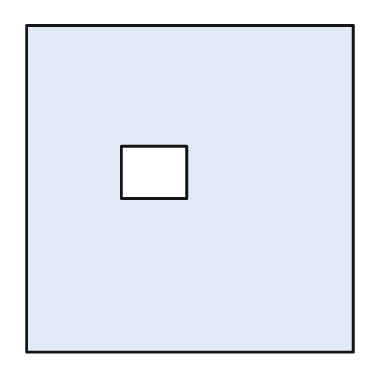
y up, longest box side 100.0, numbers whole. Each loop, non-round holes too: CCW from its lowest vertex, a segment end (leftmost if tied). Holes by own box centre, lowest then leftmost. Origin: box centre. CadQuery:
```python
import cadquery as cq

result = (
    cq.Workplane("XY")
    .moveTo(-50.0, -50.0)
    .lineTo(50.0, -50.0)
    .lineTo(50.0, 50.0)
    .lineTo(-50.0, 50.0)
    .close()
    .moveTo(-21.0, -3.0)
    .lineTo(-1.0, -3.0)
    .lineTo(-1.0, 13.0)
    .lineTo(-21.0, 13.0)
    .close()
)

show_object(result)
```